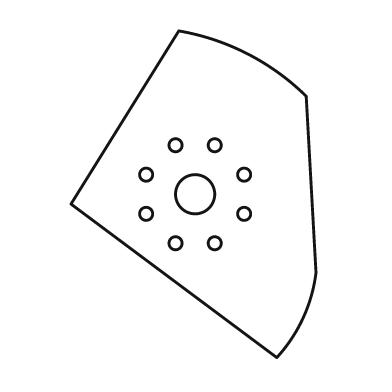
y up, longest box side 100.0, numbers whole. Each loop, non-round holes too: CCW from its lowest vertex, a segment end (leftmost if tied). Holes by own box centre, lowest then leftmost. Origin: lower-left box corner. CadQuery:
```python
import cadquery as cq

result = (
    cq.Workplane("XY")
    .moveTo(63.0, 0.0)
    .threePointArc((71.0, 12.0), (75.0, 26.0))
    .lineTo(72.0, 80.0)
    .threePointArc((54.0, 93.0), (33.0, 100.0))
    .lineTo(0.0, 47.0)
    .close()
    .moveTo(32.0, 35.0)
    .circle(2.0)
    .moveTo(44.0, 35.0)
    .circle(2.0)
    .moveTo(23.0, 44.0)
    .circle(2.0)
    .moveTo(53.0, 44.0)
    .circle(2.0)
    .moveTo(38.0, 50.0)
    .circle(6.0)
    .moveTo(23.0, 56.0)
    .circle(2.0)
    .moveTo(53.0, 56.0)
    .circle(2.0)
    .moveTo(32.0, 65.0)
    .circle(2.0)
    .moveTo(44.0, 65.0)
    .circle(2.0)
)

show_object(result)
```